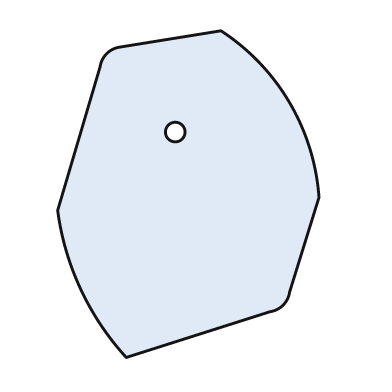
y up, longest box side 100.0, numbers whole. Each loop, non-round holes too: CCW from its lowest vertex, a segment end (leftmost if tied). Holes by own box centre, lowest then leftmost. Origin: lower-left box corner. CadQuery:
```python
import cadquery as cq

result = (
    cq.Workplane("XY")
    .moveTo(21.0, 0.0)
    .lineTo(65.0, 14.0)
    .threePointArc((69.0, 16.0), (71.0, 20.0))
    .lineTo(80.0, 49.0)
    .threePointArc((71.0, 78.0), (50.0, 100.0))
    .lineTo(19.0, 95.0)
    .threePointArc((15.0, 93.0), (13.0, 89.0))
    .lineTo(0.0, 45.0)
    .threePointArc((7.0, 21.0), (21.0, 0.0))
    .close()
    .moveTo(36.0, 69.0)
    .circle(3.0)
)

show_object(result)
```